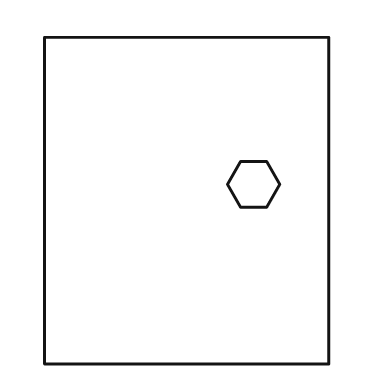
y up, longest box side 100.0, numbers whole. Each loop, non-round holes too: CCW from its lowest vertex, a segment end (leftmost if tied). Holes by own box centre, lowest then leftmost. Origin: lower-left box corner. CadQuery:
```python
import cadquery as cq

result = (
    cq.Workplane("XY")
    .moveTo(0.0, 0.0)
    .lineTo(87.0, 0.0)
    .lineTo(87.0, 100.0)
    .lineTo(0.0, 100.0)
    .close()
    .moveTo(60.0, 48.0)
    .lineTo(68.0, 48.0)
    .lineTo(72.0, 55.0)
    .lineTo(68.0, 62.0)
    .lineTo(60.0, 62.0)
    .lineTo(56.0, 55.0)
    .close()
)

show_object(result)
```